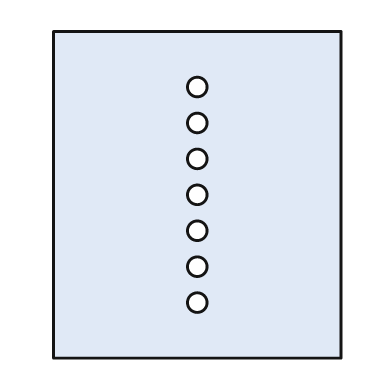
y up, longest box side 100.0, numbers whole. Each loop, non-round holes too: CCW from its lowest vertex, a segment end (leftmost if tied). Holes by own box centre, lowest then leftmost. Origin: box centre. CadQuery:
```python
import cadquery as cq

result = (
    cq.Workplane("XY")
    .moveTo(-44.0, -50.0)
    .lineTo(44.0, -50.0)
    .lineTo(44.0, 50.0)
    .lineTo(-44.0, 50.0)
    .close()
    .moveTo(0.0, -33.0)
    .circle(3.0)
    .moveTo(0.0, -22.0)
    .circle(3.0)
    .moveTo(0.0, -11.0)
    .circle(3.0)
    .moveTo(0.0, 0.0)
    .circle(3.0)
    .moveTo(0.0, 11.0)
    .circle(3.0)
    .moveTo(0.0, 22.0)
    .circle(3.0)
    .moveTo(0.0, 33.0)
    .circle(3.0)
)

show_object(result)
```